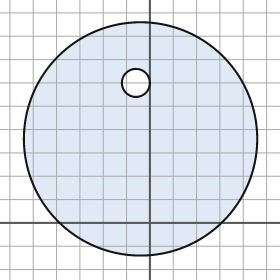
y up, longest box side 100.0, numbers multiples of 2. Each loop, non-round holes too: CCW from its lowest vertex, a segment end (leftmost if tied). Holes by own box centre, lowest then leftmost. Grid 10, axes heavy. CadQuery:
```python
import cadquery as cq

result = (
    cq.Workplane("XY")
    .moveTo(-4.0, 36.0)
    .circle(50.0)
    .moveTo(-6.0, 60.0)
    .circle(6.0)
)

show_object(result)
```